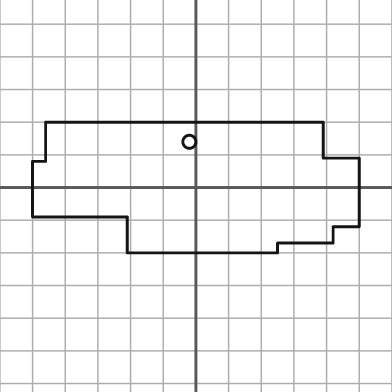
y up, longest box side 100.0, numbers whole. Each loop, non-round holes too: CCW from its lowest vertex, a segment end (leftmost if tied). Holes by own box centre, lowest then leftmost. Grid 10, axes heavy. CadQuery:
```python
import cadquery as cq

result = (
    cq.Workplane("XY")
    .moveTo(-21.0, -20.0)
    .lineTo(25.0, -20.0)
    .lineTo(25.0, -17.0)
    .lineTo(42.0, -17.0)
    .lineTo(42.0, -12.0)
    .lineTo(50.0, -12.0)
    .lineTo(50.0, 9.0)
    .lineTo(39.0, 9.0)
    .lineTo(39.0, 20.0)
    .lineTo(-46.0, 20.0)
    .lineTo(-46.0, 8.0)
    .lineTo(-50.0, 8.0)
    .lineTo(-50.0, -9.0)
    .lineTo(-21.0, -9.0)
    .close()
    .moveTo(-2.0, 14.0)
    .circle(2.0)
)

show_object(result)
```